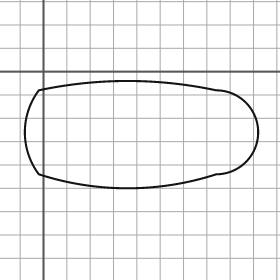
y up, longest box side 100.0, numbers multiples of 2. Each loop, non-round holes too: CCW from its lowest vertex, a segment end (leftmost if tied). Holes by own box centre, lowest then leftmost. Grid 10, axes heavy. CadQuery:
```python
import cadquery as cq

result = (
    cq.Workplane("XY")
    .moveTo(-2.0, -44.0)
    .threePointArc((36.0, -50.0), (74.0, -44.0))
    .threePointArc((92.0, -26.0), (74.0, -8.0))
    .threePointArc((36.0, -4.0), (-2.0, -8.0))
    .threePointArc((-8.0, -26.0), (-2.0, -44.0))
    .close()
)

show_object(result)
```